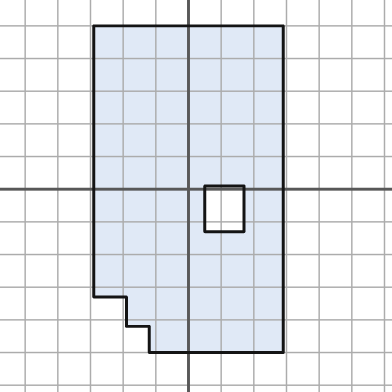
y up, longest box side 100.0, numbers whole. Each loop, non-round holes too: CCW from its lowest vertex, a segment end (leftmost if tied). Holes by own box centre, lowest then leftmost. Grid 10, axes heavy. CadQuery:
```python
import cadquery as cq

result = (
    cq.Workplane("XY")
    .moveTo(-12.0, -50.0)
    .lineTo(29.0, -50.0)
    .lineTo(29.0, 50.0)
    .lineTo(-29.0, 50.0)
    .lineTo(-29.0, -33.0)
    .lineTo(-19.0, -33.0)
    .lineTo(-19.0, -42.0)
    .lineTo(-12.0, -42.0)
    .close()
    .moveTo(5.0, -13.0)
    .lineTo(17.0, -13.0)
    .lineTo(17.0, 1.0)
    .lineTo(5.0, 1.0)
    .close()
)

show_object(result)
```